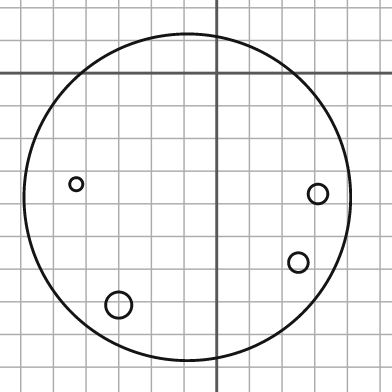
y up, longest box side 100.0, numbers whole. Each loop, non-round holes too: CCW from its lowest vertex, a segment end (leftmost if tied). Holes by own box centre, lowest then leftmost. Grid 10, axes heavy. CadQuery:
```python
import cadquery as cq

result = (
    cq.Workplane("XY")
    .moveTo(-9.0, -38.0)
    .circle(50.0)
    .moveTo(-30.0, -71.0)
    .circle(4.0)
    .moveTo(25.0, -58.0)
    .circle(3.0)
    .moveTo(31.0, -37.0)
    .circle(3.0)
    .moveTo(-43.0, -34.0)
    .circle(2.0)
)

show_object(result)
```